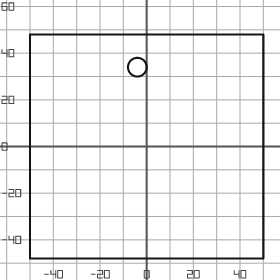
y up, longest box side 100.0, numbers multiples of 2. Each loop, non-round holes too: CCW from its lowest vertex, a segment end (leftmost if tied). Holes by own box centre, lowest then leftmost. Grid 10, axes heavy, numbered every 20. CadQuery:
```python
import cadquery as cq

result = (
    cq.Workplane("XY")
    .moveTo(-50.0, -48.0)
    .lineTo(50.0, -48.0)
    .lineTo(50.0, 48.0)
    .lineTo(-50.0, 48.0)
    .close()
    .moveTo(-4.0, 34.0)
    .circle(4.0)
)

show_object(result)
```